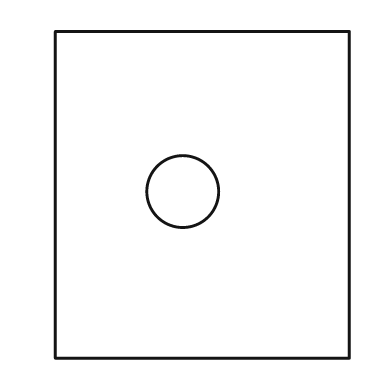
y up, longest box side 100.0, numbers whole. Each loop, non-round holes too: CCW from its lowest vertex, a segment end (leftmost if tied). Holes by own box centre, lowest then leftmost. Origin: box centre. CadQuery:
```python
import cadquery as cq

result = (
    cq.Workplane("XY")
    .moveTo(-45.0, -50.0)
    .lineTo(45.0, -50.0)
    .lineTo(45.0, 50.0)
    .lineTo(-45.0, 50.0)
    .close()
    .moveTo(-6.0, 1.0)
    .circle(11.0)
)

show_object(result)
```